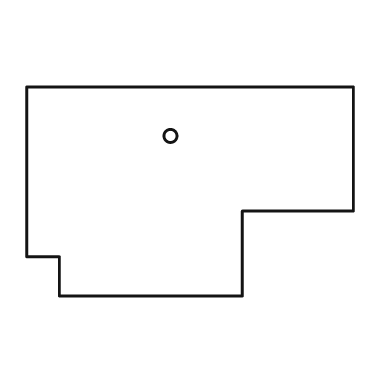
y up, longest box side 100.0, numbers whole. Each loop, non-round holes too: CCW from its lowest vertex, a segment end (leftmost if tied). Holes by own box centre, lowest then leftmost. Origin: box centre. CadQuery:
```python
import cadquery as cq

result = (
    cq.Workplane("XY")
    .moveTo(-40.0, -32.0)
    .lineTo(16.0, -32.0)
    .lineTo(16.0, -6.0)
    .lineTo(50.0, -6.0)
    .lineTo(50.0, 32.0)
    .lineTo(-50.0, 32.0)
    .lineTo(-50.0, -20.0)
    .lineTo(-40.0, -20.0)
    .close()
    .moveTo(-6.0, 17.0)
    .circle(2.0)
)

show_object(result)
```